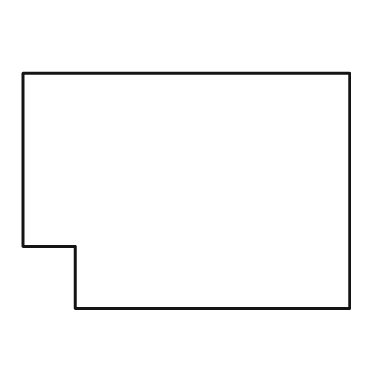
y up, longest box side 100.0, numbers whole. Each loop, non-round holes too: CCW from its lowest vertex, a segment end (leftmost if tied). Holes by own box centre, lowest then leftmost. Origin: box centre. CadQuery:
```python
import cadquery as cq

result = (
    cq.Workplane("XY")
    .moveTo(-34.0, -36.0)
    .lineTo(50.0, -36.0)
    .lineTo(50.0, 36.0)
    .lineTo(-50.0, 36.0)
    .lineTo(-50.0, -17.0)
    .lineTo(-34.0, -17.0)
    .close()
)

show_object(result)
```